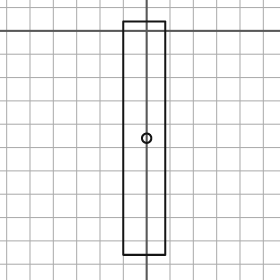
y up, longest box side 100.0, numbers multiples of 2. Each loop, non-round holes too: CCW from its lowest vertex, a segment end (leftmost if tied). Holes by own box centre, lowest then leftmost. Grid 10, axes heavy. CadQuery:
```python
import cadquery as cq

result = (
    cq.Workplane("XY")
    .moveTo(-10.0, -96.0)
    .lineTo(8.0, -96.0)
    .lineTo(8.0, 4.0)
    .lineTo(-10.0, 4.0)
    .close()
    .moveTo(0.0, -46.0)
    .circle(2.0)
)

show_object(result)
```